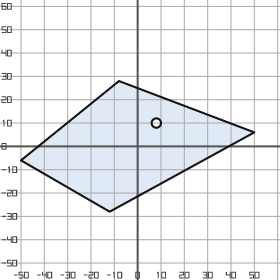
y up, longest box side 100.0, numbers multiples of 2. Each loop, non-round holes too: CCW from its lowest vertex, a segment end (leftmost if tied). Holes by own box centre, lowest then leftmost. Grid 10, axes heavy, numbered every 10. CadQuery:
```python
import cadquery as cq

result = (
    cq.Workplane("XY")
    .moveTo(-12.0, -28.0)
    .lineTo(50.0, 6.0)
    .lineTo(-8.0, 28.0)
    .lineTo(-50.0, -6.0)
    .close()
    .moveTo(8.0, 10.0)
    .circle(2.0)
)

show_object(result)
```